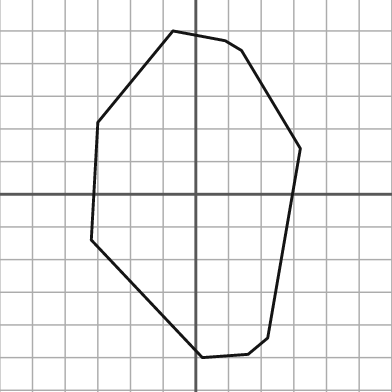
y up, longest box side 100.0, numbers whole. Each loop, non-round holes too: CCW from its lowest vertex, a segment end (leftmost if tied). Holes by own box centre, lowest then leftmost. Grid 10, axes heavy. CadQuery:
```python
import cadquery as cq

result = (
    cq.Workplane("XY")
    .moveTo(2.0, -50.0)
    .lineTo(16.0, -49.0)
    .lineTo(22.0, -44.0)
    .lineTo(32.0, 14.0)
    .lineTo(14.0, 44.0)
    .lineTo(9.0, 47.0)
    .lineTo(-7.0, 50.0)
    .lineTo(-30.0, 22.0)
    .lineTo(-32.0, -14.0)
    .close()
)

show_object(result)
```